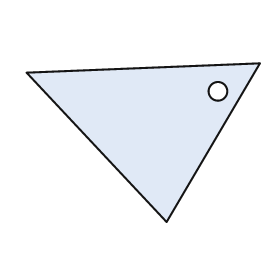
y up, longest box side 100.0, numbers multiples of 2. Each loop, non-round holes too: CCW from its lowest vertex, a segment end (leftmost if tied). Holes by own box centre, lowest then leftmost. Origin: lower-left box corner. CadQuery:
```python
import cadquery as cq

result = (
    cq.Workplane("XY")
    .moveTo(60.0, 0.0)
    .lineTo(100.0, 68.0)
    .lineTo(0.0, 64.0)
    .close()
    .moveTo(82.0, 56.0)
    .circle(4.0)
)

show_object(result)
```